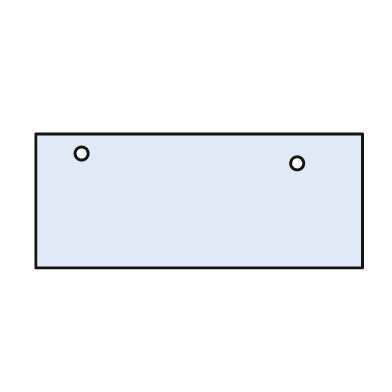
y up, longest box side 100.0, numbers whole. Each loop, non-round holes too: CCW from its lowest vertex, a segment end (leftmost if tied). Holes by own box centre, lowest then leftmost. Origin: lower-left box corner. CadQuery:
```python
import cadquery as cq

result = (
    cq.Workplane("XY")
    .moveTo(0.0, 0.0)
    .lineTo(100.0, 0.0)
    .lineTo(100.0, 41.0)
    .lineTo(0.0, 41.0)
    .close()
    .moveTo(80.0, 32.0)
    .circle(2.0)
    .moveTo(14.0, 35.0)
    .circle(2.0)
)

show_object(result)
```